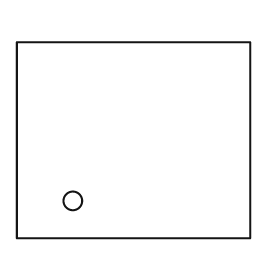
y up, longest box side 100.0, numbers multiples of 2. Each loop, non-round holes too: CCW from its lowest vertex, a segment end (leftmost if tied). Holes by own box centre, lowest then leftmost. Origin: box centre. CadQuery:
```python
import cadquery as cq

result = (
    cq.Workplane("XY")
    .moveTo(-50.0, -42.0)
    .lineTo(50.0, -42.0)
    .lineTo(50.0, 42.0)
    .lineTo(-50.0, 42.0)
    .close()
    .moveTo(-26.0, -26.0)
    .circle(4.0)
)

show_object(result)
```